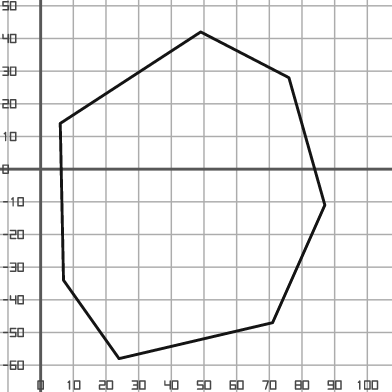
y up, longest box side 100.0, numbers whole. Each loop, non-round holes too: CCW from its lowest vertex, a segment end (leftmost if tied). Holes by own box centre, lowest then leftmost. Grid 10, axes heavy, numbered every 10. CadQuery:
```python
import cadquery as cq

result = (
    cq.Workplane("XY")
    .moveTo(24.0, -58.0)
    .lineTo(71.0, -47.0)
    .lineTo(87.0, -11.0)
    .lineTo(76.0, 28.0)
    .lineTo(49.0, 42.0)
    .lineTo(6.0, 14.0)
    .lineTo(7.0, -34.0)
    .close()
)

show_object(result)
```